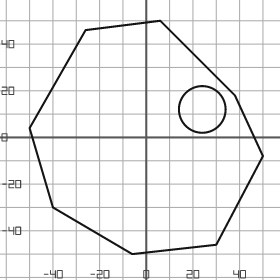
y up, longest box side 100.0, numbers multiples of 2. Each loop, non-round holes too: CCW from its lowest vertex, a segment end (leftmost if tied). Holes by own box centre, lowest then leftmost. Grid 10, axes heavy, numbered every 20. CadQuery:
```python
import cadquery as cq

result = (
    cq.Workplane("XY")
    .moveTo(-6.0, -50.0)
    .lineTo(30.0, -46.0)
    .lineTo(50.0, -8.0)
    .lineTo(38.0, 18.0)
    .lineTo(6.0, 50.0)
    .lineTo(-26.0, 46.0)
    .lineTo(-50.0, 4.0)
    .lineTo(-40.0, -30.0)
    .close()
    .moveTo(24.0, 12.0)
    .circle(10.0)
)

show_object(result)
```